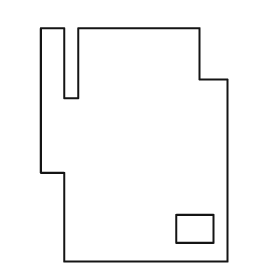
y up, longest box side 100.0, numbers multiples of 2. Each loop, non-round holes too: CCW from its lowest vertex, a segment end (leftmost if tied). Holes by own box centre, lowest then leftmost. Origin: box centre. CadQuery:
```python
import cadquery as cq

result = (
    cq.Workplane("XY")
    .moveTo(-30.0, -50.0)
    .lineTo(40.0, -50.0)
    .lineTo(40.0, 28.0)
    .lineTo(28.0, 28.0)
    .lineTo(28.0, 50.0)
    .lineTo(-24.0, 50.0)
    .lineTo(-24.0, 20.0)
    .lineTo(-30.0, 20.0)
    .lineTo(-30.0, 50.0)
    .lineTo(-40.0, 50.0)
    .lineTo(-40.0, -12.0)
    .lineTo(-30.0, -12.0)
    .close()
    .moveTo(18.0, -42.0)
    .lineTo(34.0, -42.0)
    .lineTo(34.0, -30.0)
    .lineTo(18.0, -30.0)
    .close()
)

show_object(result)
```